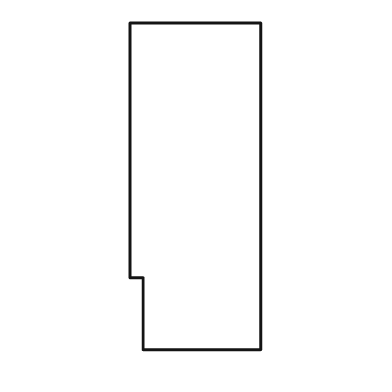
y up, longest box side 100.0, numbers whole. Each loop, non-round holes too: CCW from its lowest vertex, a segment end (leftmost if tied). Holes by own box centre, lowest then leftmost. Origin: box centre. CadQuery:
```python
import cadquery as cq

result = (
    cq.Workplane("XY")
    .moveTo(-16.0, -50.0)
    .lineTo(20.0, -50.0)
    .lineTo(20.0, 50.0)
    .lineTo(-20.0, 50.0)
    .lineTo(-20.0, -28.0)
    .lineTo(-16.0, -28.0)
    .close()
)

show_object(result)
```